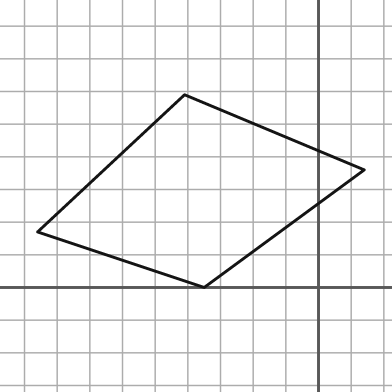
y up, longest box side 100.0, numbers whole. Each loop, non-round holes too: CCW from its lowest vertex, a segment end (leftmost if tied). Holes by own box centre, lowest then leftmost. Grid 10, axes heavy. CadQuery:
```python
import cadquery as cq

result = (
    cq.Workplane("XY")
    .moveTo(-35.0, 0.0)
    .lineTo(14.0, 36.0)
    .lineTo(-41.0, 59.0)
    .lineTo(-86.0, 17.0)
    .close()
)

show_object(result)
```